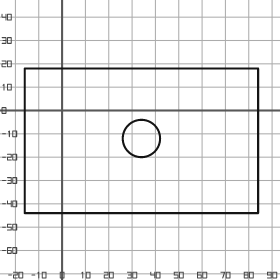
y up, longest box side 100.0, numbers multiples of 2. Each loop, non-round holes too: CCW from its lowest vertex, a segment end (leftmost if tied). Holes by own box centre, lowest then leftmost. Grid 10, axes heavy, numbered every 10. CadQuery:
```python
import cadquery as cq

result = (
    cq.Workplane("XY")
    .moveTo(-16.0, -44.0)
    .lineTo(84.0, -44.0)
    .lineTo(84.0, 18.0)
    .lineTo(-16.0, 18.0)
    .close()
    .moveTo(34.0, -12.0)
    .circle(8.0)
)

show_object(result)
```